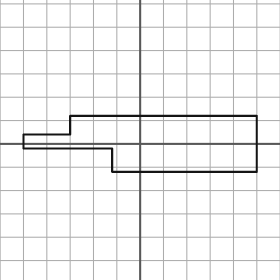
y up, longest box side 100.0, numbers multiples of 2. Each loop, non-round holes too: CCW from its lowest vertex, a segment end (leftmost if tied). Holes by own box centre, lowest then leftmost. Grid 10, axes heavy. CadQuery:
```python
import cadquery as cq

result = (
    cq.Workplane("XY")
    .moveTo(-12.0, -12.0)
    .lineTo(50.0, -12.0)
    .lineTo(50.0, 12.0)
    .lineTo(-30.0, 12.0)
    .lineTo(-30.0, 4.0)
    .lineTo(-50.0, 4.0)
    .lineTo(-50.0, -2.0)
    .lineTo(-12.0, -2.0)
    .close()
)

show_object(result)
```